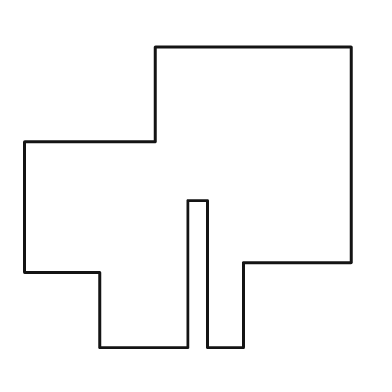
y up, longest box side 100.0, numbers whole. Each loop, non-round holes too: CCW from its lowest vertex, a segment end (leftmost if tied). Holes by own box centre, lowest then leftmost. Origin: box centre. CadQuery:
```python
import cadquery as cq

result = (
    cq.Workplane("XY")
    .moveTo(-27.0, -46.0)
    .lineTo(0.0, -46.0)
    .lineTo(0.0, -1.0)
    .lineTo(6.0, -1.0)
    .lineTo(6.0, -46.0)
    .lineTo(17.0, -46.0)
    .lineTo(17.0, -20.0)
    .lineTo(50.0, -20.0)
    .lineTo(50.0, 46.0)
    .lineTo(-10.0, 46.0)
    .lineTo(-10.0, 17.0)
    .lineTo(-50.0, 17.0)
    .lineTo(-50.0, -23.0)
    .lineTo(-27.0, -23.0)
    .close()
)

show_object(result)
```